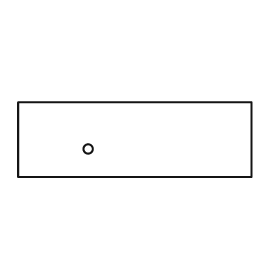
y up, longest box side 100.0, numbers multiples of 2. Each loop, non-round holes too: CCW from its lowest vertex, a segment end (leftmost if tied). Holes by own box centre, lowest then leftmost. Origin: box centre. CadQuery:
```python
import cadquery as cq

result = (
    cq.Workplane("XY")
    .moveTo(-50.0, -16.0)
    .lineTo(50.0, -16.0)
    .lineTo(50.0, 16.0)
    .lineTo(-50.0, 16.0)
    .close()
    .moveTo(-20.0, -4.0)
    .circle(2.0)
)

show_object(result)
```